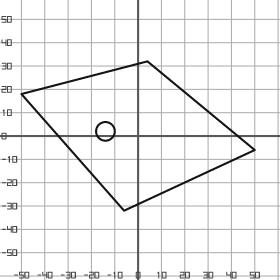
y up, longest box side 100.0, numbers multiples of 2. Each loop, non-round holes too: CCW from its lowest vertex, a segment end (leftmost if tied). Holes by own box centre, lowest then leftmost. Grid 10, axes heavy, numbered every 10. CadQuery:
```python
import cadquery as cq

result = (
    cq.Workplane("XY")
    .moveTo(-6.0, -32.0)
    .lineTo(50.0, -6.0)
    .lineTo(4.0, 32.0)
    .lineTo(-50.0, 18.0)
    .close()
    .moveTo(-14.0, 2.0)
    .circle(4.0)
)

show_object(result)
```